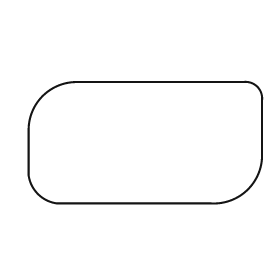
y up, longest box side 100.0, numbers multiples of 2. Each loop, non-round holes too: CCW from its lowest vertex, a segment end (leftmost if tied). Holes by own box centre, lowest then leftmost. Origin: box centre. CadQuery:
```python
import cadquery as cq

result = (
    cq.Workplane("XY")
    .moveTo(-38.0, -26.0)
    .lineTo(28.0, -26.0)
    .threePointArc((44.0, -20.0), (50.0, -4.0))
    .lineTo(50.0, 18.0)
    .threePointArc((48.0, 24.0), (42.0, 26.0))
    .lineTo(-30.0, 26.0)
    .threePointArc((-44.0, 20.0), (-50.0, 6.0))
    .lineTo(-50.0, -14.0)
    .threePointArc((-46.0, -22.0), (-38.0, -26.0))
    .close()
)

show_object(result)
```